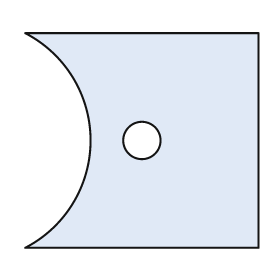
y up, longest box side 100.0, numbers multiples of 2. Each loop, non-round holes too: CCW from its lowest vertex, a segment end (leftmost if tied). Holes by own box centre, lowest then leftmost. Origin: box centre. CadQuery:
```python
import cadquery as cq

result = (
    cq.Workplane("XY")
    .moveTo(-50.0, -46.0)
    .lineTo(50.0, -46.0)
    .lineTo(50.0, 46.0)
    .lineTo(-50.0, 46.0)
    .threePointArc((-22.0, 0.0), (-50.0, -46.0))
    .close()
    .moveTo(0.0, 0.0)
    .circle(8.0)
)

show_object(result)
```